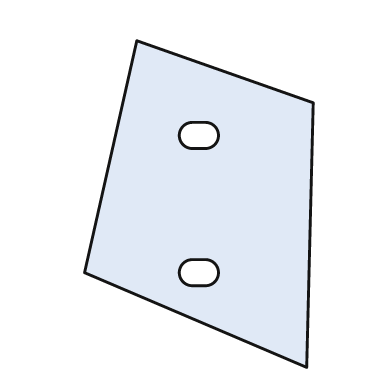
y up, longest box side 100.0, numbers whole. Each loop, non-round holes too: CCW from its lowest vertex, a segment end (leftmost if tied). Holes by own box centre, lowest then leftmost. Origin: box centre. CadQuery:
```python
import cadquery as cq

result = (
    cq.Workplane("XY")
    .moveTo(33.0, -50.0)
    .lineTo(35.0, 31.0)
    .lineTo(-19.0, 50.0)
    .lineTo(-35.0, -21.0)
    .close()
    .moveTo(-2.0, -25.0)
    .lineTo(2.0, -25.0)
    .threePointArc((6.0, -21.0), (2.0, -17.0))
    .lineTo(-2.0, -17.0)
    .threePointArc((-6.0, -21.0), (-2.0, -25.0))
    .close()
    .moveTo(-2.0, 17.0)
    .lineTo(2.0, 17.0)
    .threePointArc((6.0, 21.0), (2.0, 25.0))
    .lineTo(-2.0, 25.0)
    .threePointArc((-6.0, 21.0), (-2.0, 17.0))
    .close()
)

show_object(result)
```